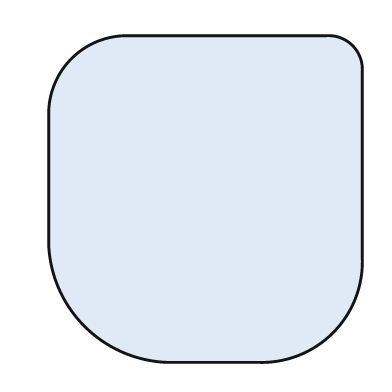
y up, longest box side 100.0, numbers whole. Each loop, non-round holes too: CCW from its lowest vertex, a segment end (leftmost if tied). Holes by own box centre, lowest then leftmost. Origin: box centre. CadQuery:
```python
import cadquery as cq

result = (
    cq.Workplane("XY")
    .moveTo(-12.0, -50.0)
    .lineTo(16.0, -50.0)
    .threePointArc((39.0, -41.0), (48.0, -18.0))
    .lineTo(48.0, 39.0)
    .threePointArc((45.0, 47.0), (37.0, 50.0))
    .lineTo(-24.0, 50.0)
    .threePointArc((-41.0, 43.0), (-48.0, 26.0))
    .lineTo(-48.0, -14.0)
    .threePointArc((-37.0, -39.0), (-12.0, -50.0))
    .close()
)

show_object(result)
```